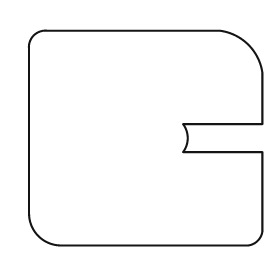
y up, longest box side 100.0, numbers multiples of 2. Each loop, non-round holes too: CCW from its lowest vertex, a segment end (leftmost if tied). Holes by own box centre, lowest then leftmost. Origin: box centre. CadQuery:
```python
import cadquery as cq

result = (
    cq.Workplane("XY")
    .moveTo(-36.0, -46.0)
    .lineTo(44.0, -46.0)
    .threePointArc((48.0, -44.0), (50.0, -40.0))
    .lineTo(50.0, -6.0)
    .lineTo(16.0, -6.0)
    .threePointArc((18.0, 0.0), (16.0, 6.0))
    .lineTo(50.0, 6.0)
    .lineTo(50.0, 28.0)
    .threePointArc((44.0, 40.0), (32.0, 46.0))
    .lineTo(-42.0, 46.0)
    .threePointArc((-48.0, 44.0), (-50.0, 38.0))
    .lineTo(-50.0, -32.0)
    .threePointArc((-46.0, -42.0), (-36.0, -46.0))
    .close()
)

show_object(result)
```